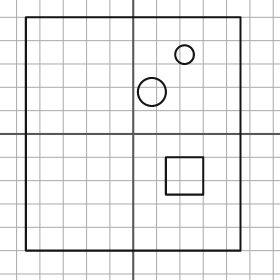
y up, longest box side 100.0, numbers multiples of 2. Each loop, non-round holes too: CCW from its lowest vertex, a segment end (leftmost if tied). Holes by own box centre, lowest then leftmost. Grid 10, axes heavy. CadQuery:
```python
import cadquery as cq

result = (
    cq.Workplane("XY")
    .moveTo(-46.0, -50.0)
    .lineTo(46.0, -50.0)
    .lineTo(46.0, 50.0)
    .lineTo(-46.0, 50.0)
    .close()
    .moveTo(14.0, -26.0)
    .lineTo(30.0, -26.0)
    .lineTo(30.0, -10.0)
    .lineTo(14.0, -10.0)
    .close()
    .moveTo(8.0, 18.0)
    .circle(6.0)
    .moveTo(22.0, 34.0)
    .circle(4.0)
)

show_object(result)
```